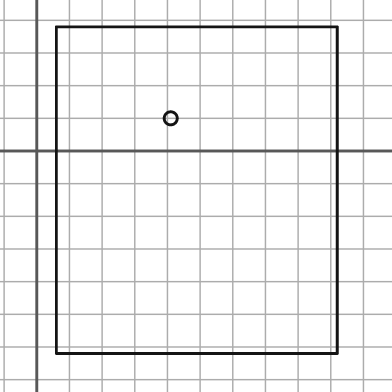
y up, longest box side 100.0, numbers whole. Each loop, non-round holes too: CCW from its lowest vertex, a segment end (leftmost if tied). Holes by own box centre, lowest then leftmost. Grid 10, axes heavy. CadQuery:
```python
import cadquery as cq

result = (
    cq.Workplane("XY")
    .moveTo(6.0, -62.0)
    .lineTo(92.0, -62.0)
    .lineTo(92.0, 38.0)
    .lineTo(6.0, 38.0)
    .close()
    .moveTo(41.0, 10.0)
    .circle(2.0)
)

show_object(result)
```